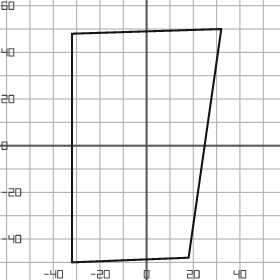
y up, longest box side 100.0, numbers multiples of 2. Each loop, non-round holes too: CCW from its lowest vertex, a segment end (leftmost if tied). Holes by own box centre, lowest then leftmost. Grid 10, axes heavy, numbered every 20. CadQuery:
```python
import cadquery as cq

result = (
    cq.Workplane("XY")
    .moveTo(-32.0, -50.0)
    .lineTo(18.0, -48.0)
    .lineTo(32.0, 50.0)
    .lineTo(-32.0, 48.0)
    .close()
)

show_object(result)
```